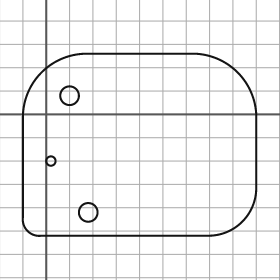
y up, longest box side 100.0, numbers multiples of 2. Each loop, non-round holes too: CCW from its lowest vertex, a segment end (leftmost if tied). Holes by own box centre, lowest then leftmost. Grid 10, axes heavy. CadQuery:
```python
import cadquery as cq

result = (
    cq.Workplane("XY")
    .moveTo(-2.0, -52.0)
    .lineTo(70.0, -52.0)
    .threePointArc((84.0, -46.0), (90.0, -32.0))
    .lineTo(90.0, 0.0)
    .threePointArc((82.0, 18.0), (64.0, 26.0))
    .lineTo(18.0, 26.0)
    .threePointArc((-2.0, 18.0), (-10.0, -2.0))
    .lineTo(-10.0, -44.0)
    .threePointArc((-8.0, -50.0), (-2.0, -52.0))
    .close()
    .moveTo(18.0, -42.0)
    .circle(4.0)
    .moveTo(2.0, -20.0)
    .circle(2.0)
    .moveTo(10.0, 8.0)
    .circle(4.0)
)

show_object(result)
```